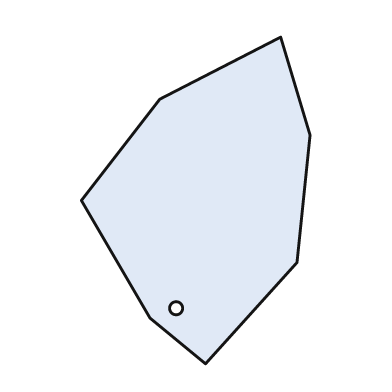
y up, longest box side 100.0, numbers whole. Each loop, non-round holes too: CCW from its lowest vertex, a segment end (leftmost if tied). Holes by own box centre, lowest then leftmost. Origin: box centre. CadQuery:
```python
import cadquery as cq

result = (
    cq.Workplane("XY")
    .moveTo(3.0, -50.0)
    .lineTo(31.0, -19.0)
    .lineTo(35.0, 20.0)
    .lineTo(26.0, 50.0)
    .lineTo(-11.0, 31.0)
    .lineTo(-35.0, 0.0)
    .lineTo(-14.0, -36.0)
    .close()
    .moveTo(-6.0, -33.0)
    .circle(2.0)
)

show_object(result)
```